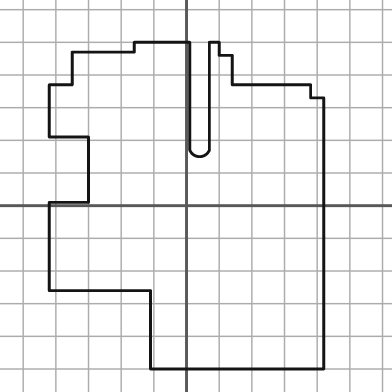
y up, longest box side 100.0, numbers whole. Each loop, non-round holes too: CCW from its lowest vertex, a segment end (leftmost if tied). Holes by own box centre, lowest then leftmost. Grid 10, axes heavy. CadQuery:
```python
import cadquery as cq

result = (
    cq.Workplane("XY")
    .moveTo(-11.0, -50.0)
    .lineTo(42.0, -50.0)
    .lineTo(42.0, 33.0)
    .lineTo(38.0, 33.0)
    .lineTo(38.0, 37.0)
    .lineTo(14.0, 37.0)
    .lineTo(14.0, 46.0)
    .lineTo(10.0, 46.0)
    .lineTo(10.0, 50.0)
    .lineTo(7.0, 50.0)
    .lineTo(7.0, 17.0)
    .threePointArc((4.0, 15.0), (1.0, 17.0))
    .lineTo(1.0, 50.0)
    .lineTo(-16.0, 50.0)
    .lineTo(-16.0, 47.0)
    .lineTo(-35.0, 47.0)
    .lineTo(-35.0, 37.0)
    .lineTo(-42.0, 37.0)
    .lineTo(-42.0, 21.0)
    .lineTo(-30.0, 21.0)
    .lineTo(-30.0, 1.0)
    .lineTo(-42.0, 1.0)
    .lineTo(-42.0, -26.0)
    .lineTo(-11.0, -26.0)
    .close()
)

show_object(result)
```